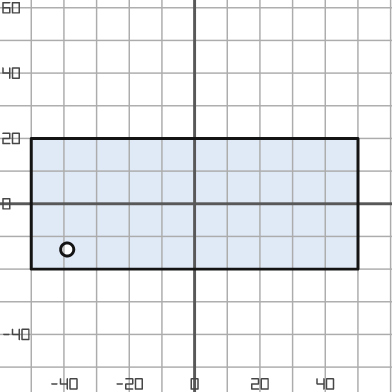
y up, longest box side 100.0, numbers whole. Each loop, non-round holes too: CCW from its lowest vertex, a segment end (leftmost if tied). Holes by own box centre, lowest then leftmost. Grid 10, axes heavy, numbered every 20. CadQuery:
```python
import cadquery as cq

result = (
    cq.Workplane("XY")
    .moveTo(-50.0, -20.0)
    .lineTo(50.0, -20.0)
    .lineTo(50.0, 20.0)
    .lineTo(-50.0, 20.0)
    .close()
    .moveTo(-39.0, -14.0)
    .circle(2.0)
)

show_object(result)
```